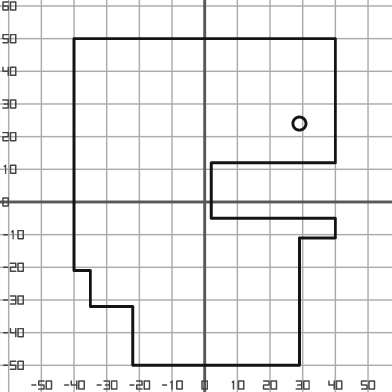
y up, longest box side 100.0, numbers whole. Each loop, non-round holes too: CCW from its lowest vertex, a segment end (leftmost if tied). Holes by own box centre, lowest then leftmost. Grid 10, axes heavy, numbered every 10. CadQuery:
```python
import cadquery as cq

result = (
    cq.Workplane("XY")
    .moveTo(-22.0, -50.0)
    .lineTo(29.0, -50.0)
    .lineTo(29.0, -11.0)
    .lineTo(40.0, -11.0)
    .lineTo(40.0, -5.0)
    .lineTo(2.0, -5.0)
    .lineTo(2.0, 12.0)
    .lineTo(40.0, 12.0)
    .lineTo(40.0, 50.0)
    .lineTo(-40.0, 50.0)
    .lineTo(-40.0, -21.0)
    .lineTo(-35.0, -21.0)
    .lineTo(-35.0, -32.0)
    .lineTo(-22.0, -32.0)
    .close()
    .moveTo(29.0, 24.0)
    .circle(2.0)
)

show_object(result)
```